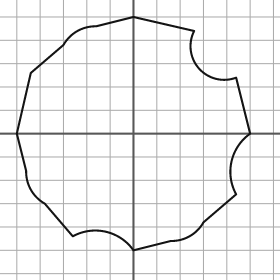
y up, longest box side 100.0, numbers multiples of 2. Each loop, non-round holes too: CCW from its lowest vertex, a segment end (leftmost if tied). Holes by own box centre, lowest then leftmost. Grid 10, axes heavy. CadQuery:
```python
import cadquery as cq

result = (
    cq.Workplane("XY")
    .moveTo(0.0, -50.0)
    .lineTo(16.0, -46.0)
    .threePointArc((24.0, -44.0), (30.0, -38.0))
    .lineTo(44.0, -26.0)
    .threePointArc((42.0, -12.0), (50.0, 0.0))
    .lineTo(44.0, 24.0)
    .threePointArc((28.0, 28.0), (26.0, 44.0))
    .lineTo(0.0, 50.0)
    .lineTo(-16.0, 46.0)
    .threePointArc((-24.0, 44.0), (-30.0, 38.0))
    .lineTo(-44.0, 26.0)
    .lineTo(-50.0, 0.0)
    .lineTo(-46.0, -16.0)
    .threePointArc((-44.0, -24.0), (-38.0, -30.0))
    .lineTo(-26.0, -44.0)
    .threePointArc((-12.0, -42.0), (0.0, -50.0))
    .close()
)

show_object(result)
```